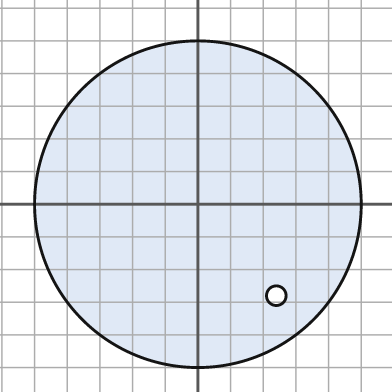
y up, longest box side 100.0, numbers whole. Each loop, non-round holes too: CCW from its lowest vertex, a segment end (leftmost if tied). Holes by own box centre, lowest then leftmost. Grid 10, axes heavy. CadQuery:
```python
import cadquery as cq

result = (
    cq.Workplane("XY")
    .moveTo(0.0, 0.0)
    .circle(50.0)
    .moveTo(24.0, -28.0)
    .circle(3.0)
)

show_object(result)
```